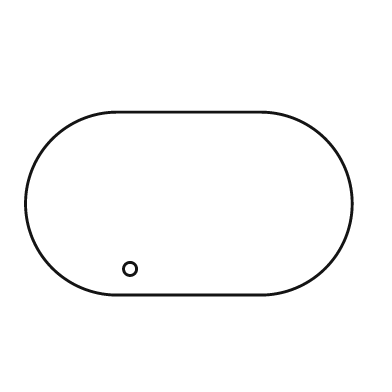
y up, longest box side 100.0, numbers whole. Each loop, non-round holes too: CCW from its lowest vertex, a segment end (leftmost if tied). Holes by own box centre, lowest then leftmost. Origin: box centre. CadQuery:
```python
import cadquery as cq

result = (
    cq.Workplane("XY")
    .moveTo(-22.0, -28.0)
    .lineTo(22.0, -28.0)
    .threePointArc((50.0, 0.0), (22.0, 28.0))
    .lineTo(-22.0, 28.0)
    .threePointArc((-50.0, 0.0), (-22.0, -28.0))
    .close()
    .moveTo(-18.0, -20.0)
    .circle(2.0)
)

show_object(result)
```